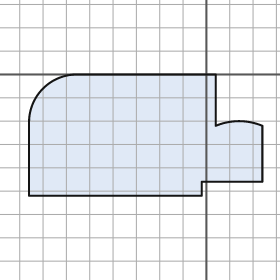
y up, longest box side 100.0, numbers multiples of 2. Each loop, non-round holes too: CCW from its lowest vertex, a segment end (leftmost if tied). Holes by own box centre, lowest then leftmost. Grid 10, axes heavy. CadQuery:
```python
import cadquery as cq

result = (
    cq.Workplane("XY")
    .moveTo(-76.0, -52.0)
    .lineTo(-2.0, -52.0)
    .lineTo(-2.0, -46.0)
    .lineTo(24.0, -46.0)
    .lineTo(24.0, -22.0)
    .threePointArc((14.0, -20.0), (4.0, -22.0))
    .lineTo(4.0, 0.0)
    .lineTo(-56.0, 0.0)
    .threePointArc((-70.0, -6.0), (-76.0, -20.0))
    .close()
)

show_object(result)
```